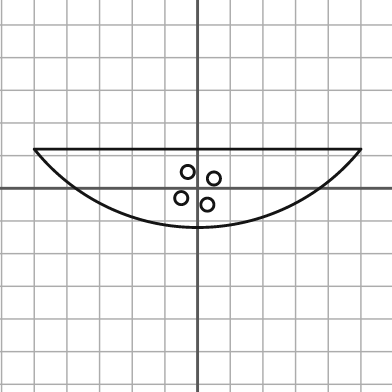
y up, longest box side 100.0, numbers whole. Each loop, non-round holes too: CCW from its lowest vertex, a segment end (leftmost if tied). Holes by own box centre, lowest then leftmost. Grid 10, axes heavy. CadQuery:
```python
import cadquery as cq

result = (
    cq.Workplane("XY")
    .moveTo(-50.0, 12.0)
    .threePointArc((0.0, -12.0), (50.0, 12.0))
    .close()
    .moveTo(3.0, -5.0)
    .circle(2.0)
    .moveTo(-5.0, -3.0)
    .circle(2.0)
    .moveTo(5.0, 3.0)
    .circle(2.0)
    .moveTo(-3.0, 5.0)
    .circle(2.0)
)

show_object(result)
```